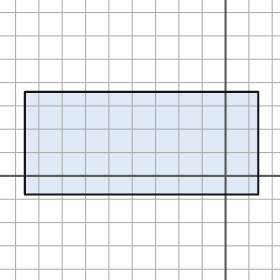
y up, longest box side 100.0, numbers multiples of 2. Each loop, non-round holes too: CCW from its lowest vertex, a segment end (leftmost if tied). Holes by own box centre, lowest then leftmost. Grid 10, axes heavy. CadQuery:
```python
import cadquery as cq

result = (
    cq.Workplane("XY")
    .moveTo(-86.0, -8.0)
    .lineTo(14.0, -8.0)
    .lineTo(14.0, 36.0)
    .lineTo(-86.0, 36.0)
    .close()
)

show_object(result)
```